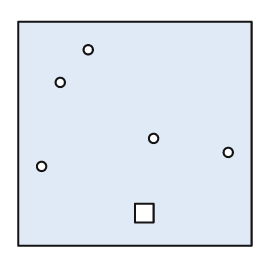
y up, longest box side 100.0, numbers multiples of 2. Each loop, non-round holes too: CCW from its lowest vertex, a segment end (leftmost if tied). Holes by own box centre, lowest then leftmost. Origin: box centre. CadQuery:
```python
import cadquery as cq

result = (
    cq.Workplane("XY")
    .moveTo(-50.0, -48.0)
    .lineTo(50.0, -48.0)
    .lineTo(50.0, 48.0)
    .lineTo(-50.0, 48.0)
    .close()
    .moveTo(0.0, -38.0)
    .lineTo(8.0, -38.0)
    .lineTo(8.0, -30.0)
    .lineTo(0.0, -30.0)
    .close()
    .moveTo(-40.0, -14.0)
    .circle(2.0)
    .moveTo(40.0, -8.0)
    .circle(2.0)
    .moveTo(8.0, -2.0)
    .circle(2.0)
    .moveTo(-32.0, 22.0)
    .circle(2.0)
    .moveTo(-20.0, 36.0)
    .circle(2.0)
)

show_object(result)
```